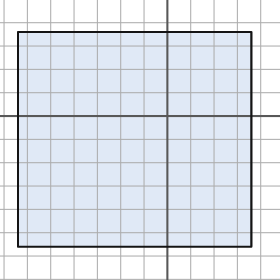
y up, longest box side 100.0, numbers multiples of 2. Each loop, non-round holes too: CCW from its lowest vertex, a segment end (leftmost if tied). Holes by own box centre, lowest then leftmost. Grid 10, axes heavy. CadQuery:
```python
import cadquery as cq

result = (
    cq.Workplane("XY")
    .moveTo(-64.0, -56.0)
    .lineTo(36.0, -56.0)
    .lineTo(36.0, 36.0)
    .lineTo(-64.0, 36.0)
    .close()
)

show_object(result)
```